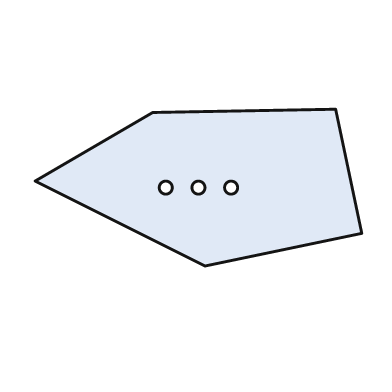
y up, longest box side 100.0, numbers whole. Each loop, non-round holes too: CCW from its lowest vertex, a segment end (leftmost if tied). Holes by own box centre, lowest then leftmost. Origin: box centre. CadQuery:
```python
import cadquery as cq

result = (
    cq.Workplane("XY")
    .moveTo(2.0, -24.0)
    .lineTo(50.0, -14.0)
    .lineTo(42.0, 24.0)
    .lineTo(-14.0, 23.0)
    .lineTo(-50.0, 2.0)
    .close()
    .moveTo(-10.0, 0.0)
    .circle(2.0)
    .moveTo(0.0, 0.0)
    .circle(2.0)
    .moveTo(10.0, 0.0)
    .circle(2.0)
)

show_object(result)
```